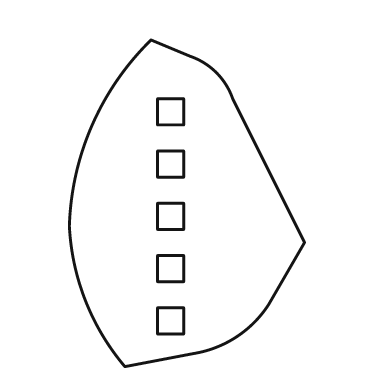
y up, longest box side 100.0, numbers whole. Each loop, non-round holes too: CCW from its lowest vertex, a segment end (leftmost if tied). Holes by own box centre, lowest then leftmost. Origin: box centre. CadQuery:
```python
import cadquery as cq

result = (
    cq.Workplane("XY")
    .moveTo(-19.0, -50.0)
    .lineTo(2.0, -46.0)
    .threePointArc((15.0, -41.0), (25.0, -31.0))
    .lineTo(36.0, -12.0)
    .lineTo(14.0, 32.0)
    .threePointArc((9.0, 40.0), (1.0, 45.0))
    .lineTo(-11.0, 50.0)
    .threePointArc((-29.0, 24.0), (-36.0, -7.0))
    .threePointArc((-31.0, -30.0), (-19.0, -50.0))
    .close()
    .moveTo(-9.0, -40.0)
    .lineTo(-1.0, -40.0)
    .lineTo(-1.0, -32.0)
    .lineTo(-9.0, -32.0)
    .close()
    .moveTo(-9.0, -24.0)
    .lineTo(-1.0, -24.0)
    .lineTo(-1.0, -16.0)
    .lineTo(-9.0, -16.0)
    .close()
    .moveTo(-9.0, -8.0)
    .lineTo(-1.0, -8.0)
    .lineTo(-1.0, 0.0)
    .lineTo(-9.0, 0.0)
    .close()
    .moveTo(-9.0, 8.0)
    .lineTo(-1.0, 8.0)
    .lineTo(-1.0, 16.0)
    .lineTo(-9.0, 16.0)
    .close()
    .moveTo(-9.0, 24.0)
    .lineTo(-1.0, 24.0)
    .lineTo(-1.0, 32.0)
    .lineTo(-9.0, 32.0)
    .close()
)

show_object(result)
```